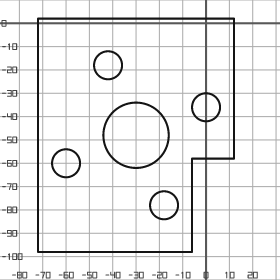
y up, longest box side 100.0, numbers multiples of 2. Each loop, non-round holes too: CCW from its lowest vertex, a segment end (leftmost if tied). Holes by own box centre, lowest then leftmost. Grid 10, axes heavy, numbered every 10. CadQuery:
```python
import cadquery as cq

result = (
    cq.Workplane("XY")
    .moveTo(-72.0, -98.0)
    .lineTo(-6.0, -98.0)
    .lineTo(-6.0, -58.0)
    .lineTo(12.0, -58.0)
    .lineTo(12.0, 2.0)
    .lineTo(-72.0, 2.0)
    .close()
    .moveTo(-18.0, -78.0)
    .circle(6.0)
    .moveTo(-60.0, -60.0)
    .circle(6.0)
    .moveTo(-30.0, -48.0)
    .circle(14.0)
    .moveTo(0.0, -36.0)
    .circle(6.0)
    .moveTo(-42.0, -18.0)
    .circle(6.0)
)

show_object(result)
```